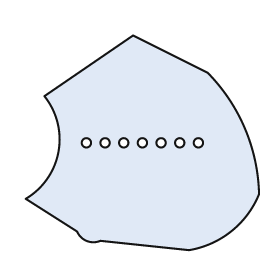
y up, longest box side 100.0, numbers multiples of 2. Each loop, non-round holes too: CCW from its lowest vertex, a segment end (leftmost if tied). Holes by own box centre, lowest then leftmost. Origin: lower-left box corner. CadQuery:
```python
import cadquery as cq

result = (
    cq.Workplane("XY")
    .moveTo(70.0, 0.0)
    .threePointArc((88.0, 8.0), (100.0, 24.0))
    .threePointArc((94.0, 52.0), (78.0, 76.0))
    .lineTo(46.0, 92.0)
    .lineTo(8.0, 66.0)
    .threePointArc((14.0, 42.0), (0.0, 22.0))
    .lineTo(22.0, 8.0)
    .threePointArc((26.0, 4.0), (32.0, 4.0))
    .close()
    .moveTo(26.0, 46.0)
    .circle(2.0)
    .moveTo(34.0, 46.0)
    .circle(2.0)
    .moveTo(42.0, 46.0)
    .circle(2.0)
    .moveTo(50.0, 46.0)
    .circle(2.0)
    .moveTo(58.0, 46.0)
    .circle(2.0)
    .moveTo(66.0, 46.0)
    .circle(2.0)
    .moveTo(74.0, 46.0)
    .circle(2.0)
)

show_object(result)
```